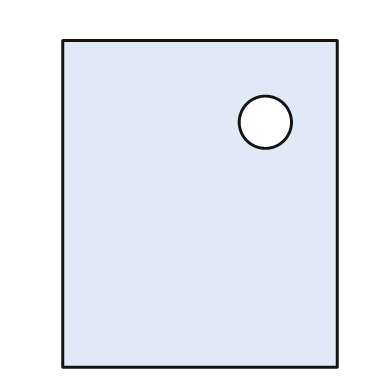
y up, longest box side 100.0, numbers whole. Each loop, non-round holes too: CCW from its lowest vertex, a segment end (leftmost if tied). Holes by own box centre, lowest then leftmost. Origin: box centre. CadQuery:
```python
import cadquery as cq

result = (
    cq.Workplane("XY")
    .moveTo(-42.0, -50.0)
    .lineTo(42.0, -50.0)
    .lineTo(42.0, 50.0)
    .lineTo(-42.0, 50.0)
    .close()
    .moveTo(20.0, 25.0)
    .circle(8.0)
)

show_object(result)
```